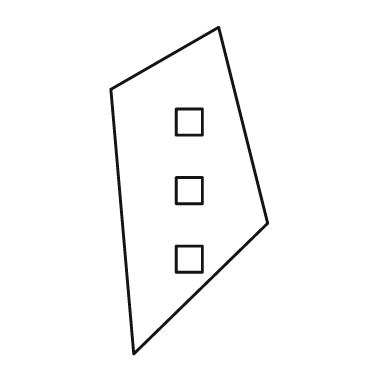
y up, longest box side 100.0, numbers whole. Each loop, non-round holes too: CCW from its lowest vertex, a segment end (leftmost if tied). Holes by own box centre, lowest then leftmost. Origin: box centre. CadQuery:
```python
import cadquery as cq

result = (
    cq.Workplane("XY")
    .moveTo(-17.0, -50.0)
    .lineTo(24.0, -10.0)
    .lineTo(9.0, 50.0)
    .lineTo(-24.0, 31.0)
    .close()
    .moveTo(-4.0, -25.0)
    .lineTo(4.0, -25.0)
    .lineTo(4.0, -17.0)
    .lineTo(-4.0, -17.0)
    .close()
    .moveTo(-4.0, -4.0)
    .lineTo(4.0, -4.0)
    .lineTo(4.0, 4.0)
    .lineTo(-4.0, 4.0)
    .close()
    .moveTo(-4.0, 17.0)
    .lineTo(4.0, 17.0)
    .lineTo(4.0, 25.0)
    .lineTo(-4.0, 25.0)
    .close()
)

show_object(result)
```